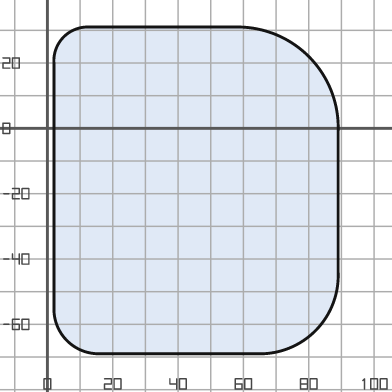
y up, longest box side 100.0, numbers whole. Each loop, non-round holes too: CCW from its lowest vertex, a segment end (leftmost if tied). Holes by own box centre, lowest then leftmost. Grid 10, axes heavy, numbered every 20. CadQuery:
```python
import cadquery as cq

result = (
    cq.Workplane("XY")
    .moveTo(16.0, -69.0)
    .lineTo(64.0, -69.0)
    .threePointArc((82.0, -62.0), (89.0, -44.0))
    .lineTo(89.0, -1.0)
    .threePointArc((80.0, 22.0), (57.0, 31.0))
    .lineTo(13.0, 31.0)
    .threePointArc((5.0, 28.0), (2.0, 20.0))
    .lineTo(2.0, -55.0)
    .threePointArc((6.0, -65.0), (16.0, -69.0))
    .close()
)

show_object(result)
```